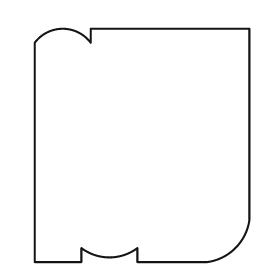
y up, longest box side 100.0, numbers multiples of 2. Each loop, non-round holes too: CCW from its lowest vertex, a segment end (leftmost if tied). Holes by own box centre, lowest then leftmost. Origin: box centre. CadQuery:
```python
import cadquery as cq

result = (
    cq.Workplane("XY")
    .moveTo(-46.0, -50.0)
    .lineTo(-26.0, -50.0)
    .lineTo(-26.0, -44.0)
    .threePointArc((-14.0, -48.0), (-2.0, -44.0))
    .lineTo(-2.0, -50.0)
    .lineTo(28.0, -50.0)
    .threePointArc((40.0, -44.0), (46.0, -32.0))
    .lineTo(46.0, 50.0)
    .lineTo(-22.0, 50.0)
    .lineTo(-22.0, 44.0)
    .threePointArc((-34.0, 50.0), (-46.0, 44.0))
    .close()
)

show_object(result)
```